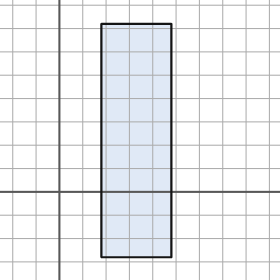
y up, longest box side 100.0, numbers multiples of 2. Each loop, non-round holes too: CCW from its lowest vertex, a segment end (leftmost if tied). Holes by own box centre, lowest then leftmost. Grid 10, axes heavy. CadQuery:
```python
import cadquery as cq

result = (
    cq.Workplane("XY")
    .moveTo(18.0, -28.0)
    .lineTo(48.0, -28.0)
    .lineTo(48.0, 72.0)
    .lineTo(18.0, 72.0)
    .close()
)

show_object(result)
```